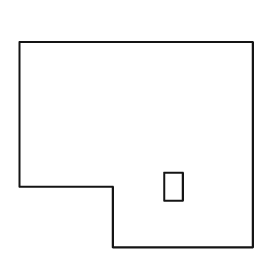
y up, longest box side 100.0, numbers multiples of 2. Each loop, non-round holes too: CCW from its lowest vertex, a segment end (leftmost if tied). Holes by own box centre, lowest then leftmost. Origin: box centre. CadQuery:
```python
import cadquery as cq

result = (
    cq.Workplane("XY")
    .moveTo(-10.0, -44.0)
    .lineTo(50.0, -44.0)
    .lineTo(50.0, 44.0)
    .lineTo(-50.0, 44.0)
    .lineTo(-50.0, -18.0)
    .lineTo(-10.0, -18.0)
    .close()
    .moveTo(12.0, -24.0)
    .lineTo(20.0, -24.0)
    .lineTo(20.0, -12.0)
    .lineTo(12.0, -12.0)
    .close()
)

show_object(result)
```